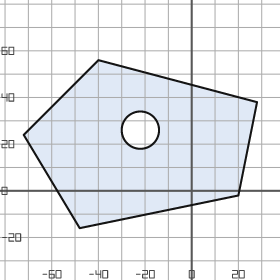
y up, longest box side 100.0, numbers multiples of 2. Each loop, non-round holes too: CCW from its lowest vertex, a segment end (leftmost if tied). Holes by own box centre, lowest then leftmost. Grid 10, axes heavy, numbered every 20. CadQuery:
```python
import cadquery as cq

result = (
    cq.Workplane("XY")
    .moveTo(-48.0, -16.0)
    .lineTo(20.0, -2.0)
    .lineTo(28.0, 38.0)
    .lineTo(-40.0, 56.0)
    .lineTo(-72.0, 24.0)
    .close()
    .moveTo(-22.0, 26.0)
    .circle(8.0)
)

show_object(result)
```